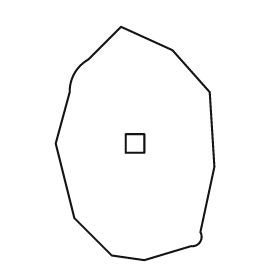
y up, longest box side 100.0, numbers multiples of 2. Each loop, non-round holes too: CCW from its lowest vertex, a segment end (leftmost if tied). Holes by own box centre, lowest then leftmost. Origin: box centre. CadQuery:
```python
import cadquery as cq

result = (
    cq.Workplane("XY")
    .moveTo(4.0, -50.0)
    .lineTo(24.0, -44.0)
    .threePointArc((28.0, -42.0), (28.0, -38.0))
    .lineTo(34.0, -10.0)
    .lineTo(32.0, 22.0)
    .lineTo(16.0, 40.0)
    .lineTo(-6.0, 50.0)
    .lineTo(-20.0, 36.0)
    .threePointArc((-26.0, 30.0), (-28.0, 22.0))
    .lineTo(-34.0, 0.0)
    .lineTo(-26.0, -32.0)
    .lineTo(-10.0, -48.0)
    .close()
    .moveTo(-4.0, -4.0)
    .lineTo(4.0, -4.0)
    .lineTo(4.0, 4.0)
    .lineTo(-4.0, 4.0)
    .close()
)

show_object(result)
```